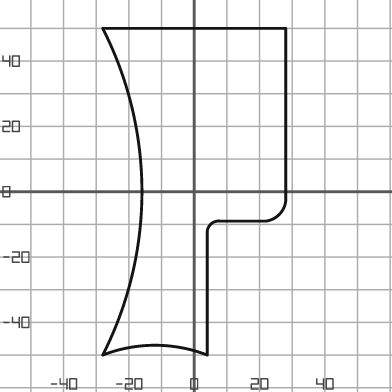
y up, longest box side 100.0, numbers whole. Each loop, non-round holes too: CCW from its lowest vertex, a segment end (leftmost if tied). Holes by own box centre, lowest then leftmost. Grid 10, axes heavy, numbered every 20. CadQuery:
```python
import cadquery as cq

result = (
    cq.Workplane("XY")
    .moveTo(-28.0, -50.0)
    .threePointArc((-12.0, -47.0), (4.0, -50.0))
    .lineTo(4.0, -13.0)
    .threePointArc((5.0, -10.0), (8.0, -9.0))
    .lineTo(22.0, -9.0)
    .threePointArc((26.0, -7.0), (28.0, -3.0))
    .lineTo(28.0, 50.0)
    .lineTo(-28.0, 50.0)
    .threePointArc((-16.0, 0.0), (-28.0, -50.0))
    .close()
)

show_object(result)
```